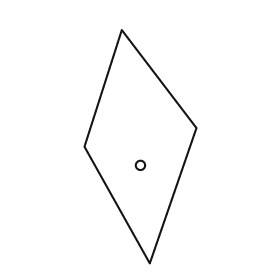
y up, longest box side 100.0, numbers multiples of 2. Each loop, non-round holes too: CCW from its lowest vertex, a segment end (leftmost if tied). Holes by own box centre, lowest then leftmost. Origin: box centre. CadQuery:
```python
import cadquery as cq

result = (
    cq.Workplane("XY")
    .moveTo(4.0, -50.0)
    .lineTo(24.0, 8.0)
    .lineTo(-8.0, 50.0)
    .lineTo(-24.0, 0.0)
    .close()
    .moveTo(0.0, -8.0)
    .circle(2.0)
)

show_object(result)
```